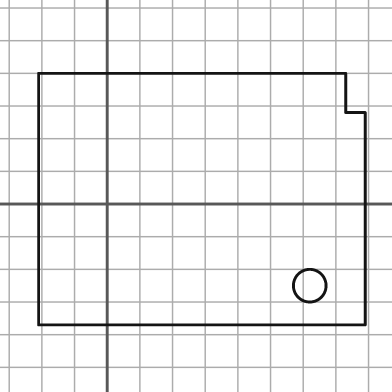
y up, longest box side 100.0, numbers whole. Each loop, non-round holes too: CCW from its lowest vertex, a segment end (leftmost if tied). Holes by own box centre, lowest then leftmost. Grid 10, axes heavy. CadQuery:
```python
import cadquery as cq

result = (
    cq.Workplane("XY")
    .moveTo(-21.0, -37.0)
    .lineTo(79.0, -37.0)
    .lineTo(79.0, 28.0)
    .lineTo(73.0, 28.0)
    .lineTo(73.0, 40.0)
    .lineTo(-21.0, 40.0)
    .close()
    .moveTo(62.0, -25.0)
    .circle(5.0)
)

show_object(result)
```